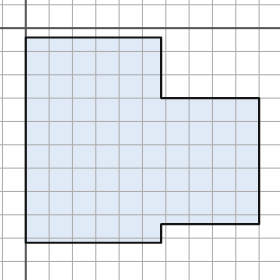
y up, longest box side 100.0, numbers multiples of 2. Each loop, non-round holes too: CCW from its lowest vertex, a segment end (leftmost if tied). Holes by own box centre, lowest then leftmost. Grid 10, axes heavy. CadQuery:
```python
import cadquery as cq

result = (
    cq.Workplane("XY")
    .moveTo(0.0, -92.0)
    .lineTo(58.0, -92.0)
    .lineTo(58.0, -84.0)
    .lineTo(100.0, -84.0)
    .lineTo(100.0, -30.0)
    .lineTo(58.0, -30.0)
    .lineTo(58.0, -4.0)
    .lineTo(0.0, -4.0)
    .close()
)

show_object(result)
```